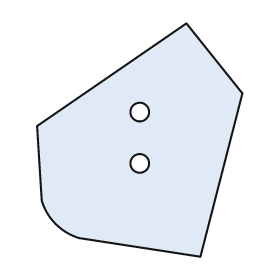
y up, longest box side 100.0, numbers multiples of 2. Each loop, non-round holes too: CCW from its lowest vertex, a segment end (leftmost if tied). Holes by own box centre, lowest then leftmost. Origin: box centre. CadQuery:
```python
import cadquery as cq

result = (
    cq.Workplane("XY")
    .moveTo(26.0, -50.0)
    .lineTo(44.0, 20.0)
    .lineTo(20.0, 50.0)
    .lineTo(-44.0, 6.0)
    .lineTo(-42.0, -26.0)
    .threePointArc((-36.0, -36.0), (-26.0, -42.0))
    .close()
    .moveTo(0.0, -10.0)
    .circle(4.0)
    .moveTo(0.0, 12.0)
    .circle(4.0)
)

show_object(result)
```